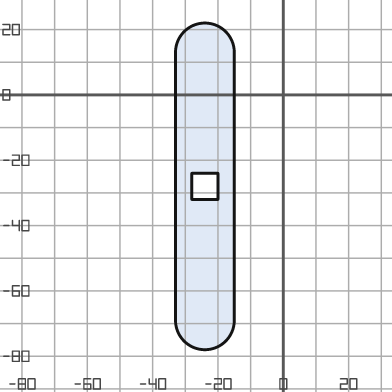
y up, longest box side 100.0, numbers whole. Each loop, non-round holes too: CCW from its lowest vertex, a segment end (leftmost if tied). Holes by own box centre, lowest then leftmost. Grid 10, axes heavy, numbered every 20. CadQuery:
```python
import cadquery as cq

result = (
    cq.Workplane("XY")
    .moveTo(-33.0, -69.0)
    .threePointArc((-24.0, -78.0), (-15.0, -69.0))
    .lineTo(-15.0, 13.0)
    .threePointArc((-24.0, 22.0), (-33.0, 13.0))
    .close()
    .moveTo(-28.0, -32.0)
    .lineTo(-20.0, -32.0)
    .lineTo(-20.0, -24.0)
    .lineTo(-28.0, -24.0)
    .close()
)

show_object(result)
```